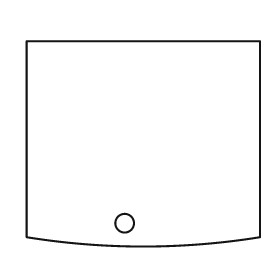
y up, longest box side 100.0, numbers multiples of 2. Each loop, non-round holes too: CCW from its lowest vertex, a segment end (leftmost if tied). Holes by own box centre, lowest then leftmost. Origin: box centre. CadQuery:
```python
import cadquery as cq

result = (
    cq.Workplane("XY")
    .moveTo(-50.0, -40.0)
    .threePointArc((0.0, -44.0), (50.0, -40.0))
    .lineTo(50.0, 44.0)
    .lineTo(-50.0, 44.0)
    .close()
    .moveTo(-8.0, -34.0)
    .circle(4.0)
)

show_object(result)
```